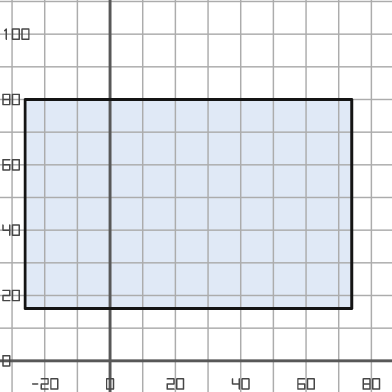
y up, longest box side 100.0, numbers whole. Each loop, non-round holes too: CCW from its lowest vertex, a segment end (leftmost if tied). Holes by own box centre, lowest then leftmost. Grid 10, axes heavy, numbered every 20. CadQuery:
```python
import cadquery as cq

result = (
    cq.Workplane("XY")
    .moveTo(-26.0, 16.0)
    .lineTo(74.0, 16.0)
    .lineTo(74.0, 80.0)
    .lineTo(-26.0, 80.0)
    .close()
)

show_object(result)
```